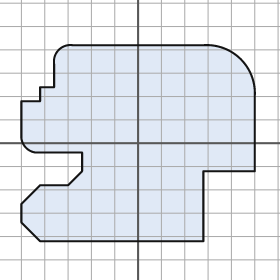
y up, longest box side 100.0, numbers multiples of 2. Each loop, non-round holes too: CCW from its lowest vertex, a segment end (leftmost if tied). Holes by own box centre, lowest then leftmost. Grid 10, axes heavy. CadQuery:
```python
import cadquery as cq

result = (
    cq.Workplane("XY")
    .moveTo(-42.0, -42.0)
    .lineTo(28.0, -42.0)
    .lineTo(28.0, -12.0)
    .lineTo(50.0, -12.0)
    .lineTo(50.0, 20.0)
    .threePointArc((44.0, 36.0), (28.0, 42.0))
    .lineTo(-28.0, 42.0)
    .threePointArc((-34.0, 40.0), (-36.0, 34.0))
    .lineTo(-36.0, 24.0)
    .lineTo(-42.0, 24.0)
    .lineTo(-42.0, 18.0)
    .lineTo(-50.0, 18.0)
    .lineTo(-50.0, 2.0)
    .threePointArc((-48.0, -2.0), (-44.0, -4.0))
    .lineTo(-24.0, -4.0)
    .lineTo(-24.0, -12.0)
    .lineTo(-30.0, -18.0)
    .lineTo(-42.0, -18.0)
    .lineTo(-50.0, -26.0)
    .lineTo(-50.0, -34.0)
    .close()
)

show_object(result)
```